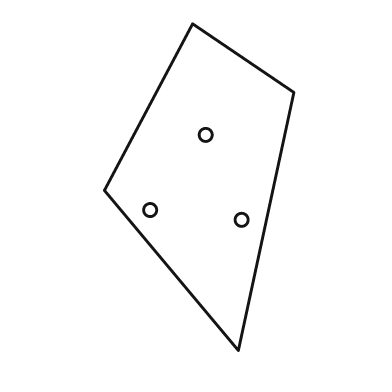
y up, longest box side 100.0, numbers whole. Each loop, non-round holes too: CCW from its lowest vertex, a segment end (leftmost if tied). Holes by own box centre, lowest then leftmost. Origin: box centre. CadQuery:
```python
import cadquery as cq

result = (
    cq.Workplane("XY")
    .moveTo(12.0, -50.0)
    .lineTo(29.0, 29.0)
    .lineTo(-2.0, 50.0)
    .lineTo(-29.0, -1.0)
    .close()
    .moveTo(13.0, -10.0)
    .circle(2.0)
    .moveTo(-15.0, -7.0)
    .circle(2.0)
    .moveTo(2.0, 16.0)
    .circle(2.0)
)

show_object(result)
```